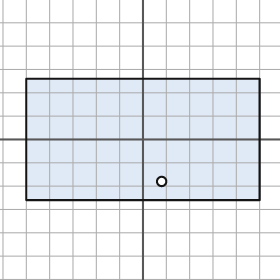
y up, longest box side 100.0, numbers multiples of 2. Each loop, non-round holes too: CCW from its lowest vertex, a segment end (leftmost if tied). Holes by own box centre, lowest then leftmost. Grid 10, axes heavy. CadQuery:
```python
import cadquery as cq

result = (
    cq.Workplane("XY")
    .moveTo(-50.0, -26.0)
    .lineTo(50.0, -26.0)
    .lineTo(50.0, 26.0)
    .lineTo(-50.0, 26.0)
    .close()
    .moveTo(8.0, -18.0)
    .circle(2.0)
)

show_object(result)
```